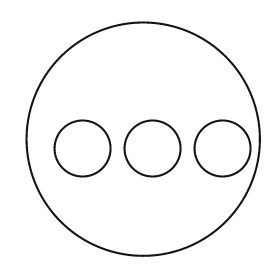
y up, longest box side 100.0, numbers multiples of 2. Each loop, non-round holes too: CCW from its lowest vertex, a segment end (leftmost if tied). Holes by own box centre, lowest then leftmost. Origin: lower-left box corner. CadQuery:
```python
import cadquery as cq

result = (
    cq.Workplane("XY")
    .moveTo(50.0, 50.0)
    .circle(50.0)
    .moveTo(24.0, 46.0)
    .circle(12.0)
    .moveTo(54.0, 46.0)
    .circle(12.0)
    .moveTo(84.0, 46.0)
    .circle(12.0)
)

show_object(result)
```